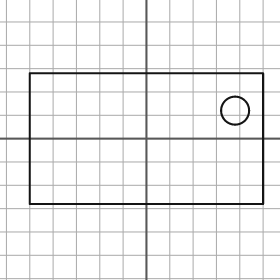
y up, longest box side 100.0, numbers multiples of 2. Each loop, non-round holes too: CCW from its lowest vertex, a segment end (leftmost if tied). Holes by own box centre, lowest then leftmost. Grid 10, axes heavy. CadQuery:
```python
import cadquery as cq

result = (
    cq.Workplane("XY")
    .moveTo(-50.0, -28.0)
    .lineTo(50.0, -28.0)
    .lineTo(50.0, 28.0)
    .lineTo(-50.0, 28.0)
    .close()
    .moveTo(38.0, 12.0)
    .circle(6.0)
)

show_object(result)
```